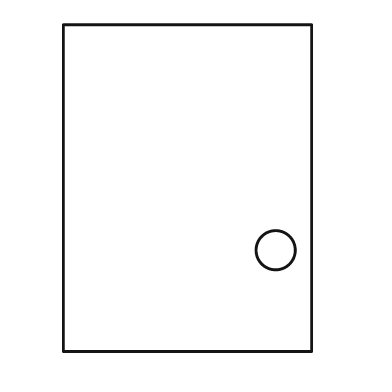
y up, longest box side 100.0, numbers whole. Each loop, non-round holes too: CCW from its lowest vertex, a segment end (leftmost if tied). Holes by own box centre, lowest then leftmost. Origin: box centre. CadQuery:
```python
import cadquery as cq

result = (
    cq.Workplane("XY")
    .moveTo(-38.0, -50.0)
    .lineTo(38.0, -50.0)
    .lineTo(38.0, 50.0)
    .lineTo(-38.0, 50.0)
    .close()
    .moveTo(27.0, -19.0)
    .circle(6.0)
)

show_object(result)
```